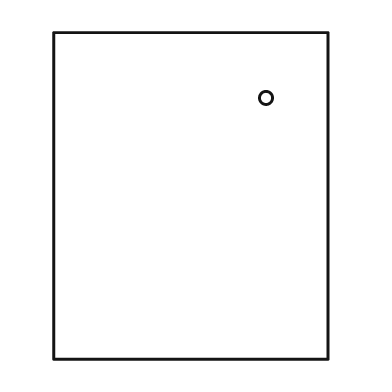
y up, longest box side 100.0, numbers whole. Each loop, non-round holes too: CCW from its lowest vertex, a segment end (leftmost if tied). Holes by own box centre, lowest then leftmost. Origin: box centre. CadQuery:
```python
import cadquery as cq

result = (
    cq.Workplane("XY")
    .moveTo(-42.0, -50.0)
    .lineTo(42.0, -50.0)
    .lineTo(42.0, 50.0)
    .lineTo(-42.0, 50.0)
    .close()
    .moveTo(23.0, 30.0)
    .circle(2.0)
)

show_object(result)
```